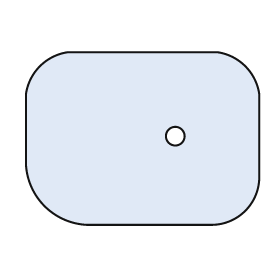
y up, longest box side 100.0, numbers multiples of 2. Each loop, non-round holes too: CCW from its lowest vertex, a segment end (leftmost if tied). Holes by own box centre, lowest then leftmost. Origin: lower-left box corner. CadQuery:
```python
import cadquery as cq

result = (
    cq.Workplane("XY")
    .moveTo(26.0, 0.0)
    .lineTo(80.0, 0.0)
    .threePointArc((94.0, 6.0), (100.0, 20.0))
    .lineTo(100.0, 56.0)
    .threePointArc((94.0, 68.0), (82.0, 74.0))
    .lineTo(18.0, 74.0)
    .threePointArc((6.0, 68.0), (0.0, 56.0))
    .lineTo(0.0, 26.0)
    .threePointArc((8.0, 8.0), (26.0, 0.0))
    .close()
    .moveTo(64.0, 38.0)
    .circle(4.0)
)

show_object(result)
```